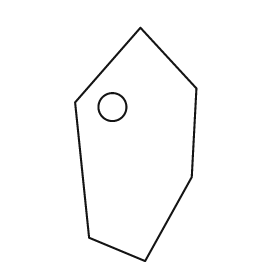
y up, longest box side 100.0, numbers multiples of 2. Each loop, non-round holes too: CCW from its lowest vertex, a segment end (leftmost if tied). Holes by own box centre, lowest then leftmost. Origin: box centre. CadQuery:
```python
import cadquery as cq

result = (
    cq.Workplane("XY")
    .moveTo(4.0, -50.0)
    .lineTo(24.0, -14.0)
    .lineTo(26.0, 24.0)
    .lineTo(2.0, 50.0)
    .lineTo(-26.0, 18.0)
    .lineTo(-20.0, -40.0)
    .close()
    .moveTo(-10.0, 16.0)
    .circle(6.0)
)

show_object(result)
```